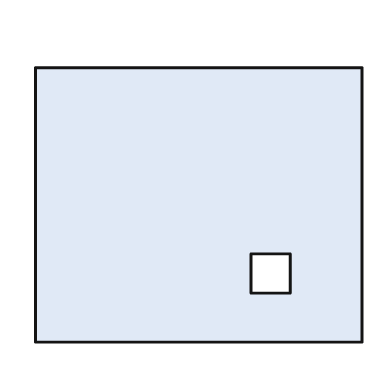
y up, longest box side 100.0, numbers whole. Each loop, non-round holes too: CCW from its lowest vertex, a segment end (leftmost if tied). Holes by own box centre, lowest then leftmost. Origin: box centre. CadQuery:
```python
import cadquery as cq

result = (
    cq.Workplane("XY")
    .moveTo(-50.0, -42.0)
    .lineTo(50.0, -42.0)
    .lineTo(50.0, 42.0)
    .lineTo(-50.0, 42.0)
    .close()
    .moveTo(16.0, -27.0)
    .lineTo(28.0, -27.0)
    .lineTo(28.0, -15.0)
    .lineTo(16.0, -15.0)
    .close()
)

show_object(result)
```